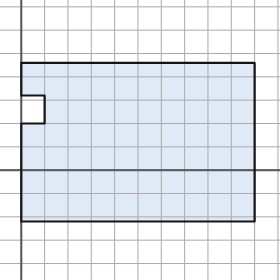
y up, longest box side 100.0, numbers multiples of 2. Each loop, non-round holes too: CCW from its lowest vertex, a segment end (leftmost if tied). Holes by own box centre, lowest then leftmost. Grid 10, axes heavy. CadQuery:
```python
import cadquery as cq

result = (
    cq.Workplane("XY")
    .moveTo(0.0, -22.0)
    .lineTo(100.0, -22.0)
    .lineTo(100.0, 46.0)
    .lineTo(0.0, 46.0)
    .lineTo(0.0, 32.0)
    .lineTo(10.0, 32.0)
    .lineTo(10.0, 20.0)
    .lineTo(0.0, 20.0)
    .close()
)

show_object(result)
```